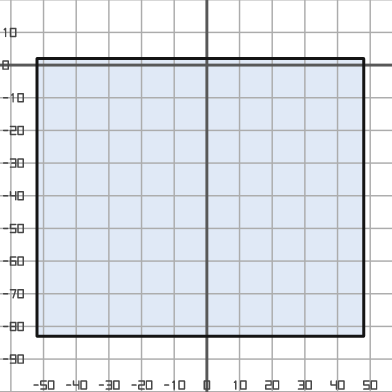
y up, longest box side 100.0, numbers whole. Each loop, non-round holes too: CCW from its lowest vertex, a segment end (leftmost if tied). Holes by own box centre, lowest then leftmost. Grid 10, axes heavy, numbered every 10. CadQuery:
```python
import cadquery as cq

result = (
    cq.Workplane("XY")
    .moveTo(-52.0, -83.0)
    .lineTo(48.0, -83.0)
    .lineTo(48.0, 2.0)
    .lineTo(-52.0, 2.0)
    .close()
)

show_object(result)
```